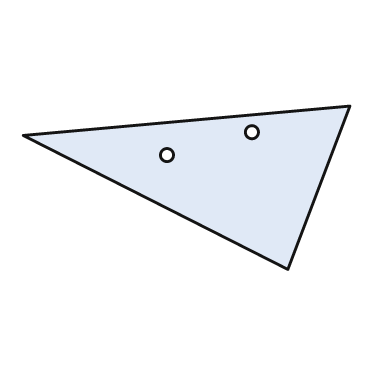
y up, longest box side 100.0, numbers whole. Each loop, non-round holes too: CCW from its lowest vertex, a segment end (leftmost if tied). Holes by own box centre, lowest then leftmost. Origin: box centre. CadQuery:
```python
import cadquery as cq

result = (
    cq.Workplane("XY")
    .moveTo(31.0, -25.0)
    .lineTo(50.0, 25.0)
    .lineTo(-50.0, 16.0)
    .close()
    .moveTo(-6.0, 10.0)
    .circle(2.0)
    .moveTo(20.0, 17.0)
    .circle(2.0)
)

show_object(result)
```